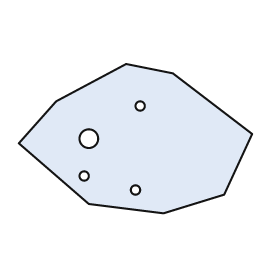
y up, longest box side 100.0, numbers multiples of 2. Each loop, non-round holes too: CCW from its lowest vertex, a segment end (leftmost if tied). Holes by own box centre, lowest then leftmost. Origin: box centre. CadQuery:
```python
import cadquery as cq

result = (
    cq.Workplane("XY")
    .moveTo(12.0, -32.0)
    .lineTo(38.0, -24.0)
    .lineTo(50.0, 2.0)
    .lineTo(16.0, 28.0)
    .lineTo(-4.0, 32.0)
    .lineTo(-34.0, 16.0)
    .lineTo(-50.0, -2.0)
    .lineTo(-20.0, -28.0)
    .close()
    .moveTo(0.0, -22.0)
    .circle(2.0)
    .moveTo(-22.0, -16.0)
    .circle(2.0)
    .moveTo(-20.0, 0.0)
    .circle(4.0)
    .moveTo(2.0, 14.0)
    .circle(2.0)
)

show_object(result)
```